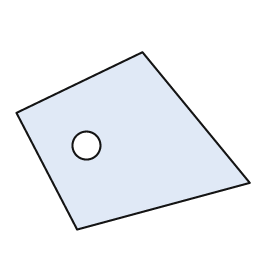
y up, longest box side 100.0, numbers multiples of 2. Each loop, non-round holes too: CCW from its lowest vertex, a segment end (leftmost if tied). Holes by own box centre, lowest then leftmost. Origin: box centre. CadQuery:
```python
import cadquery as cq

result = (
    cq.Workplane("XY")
    .moveTo(-24.0, -38.0)
    .lineTo(50.0, -18.0)
    .lineTo(4.0, 38.0)
    .lineTo(-50.0, 12.0)
    .close()
    .moveTo(-20.0, -2.0)
    .circle(6.0)
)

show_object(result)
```